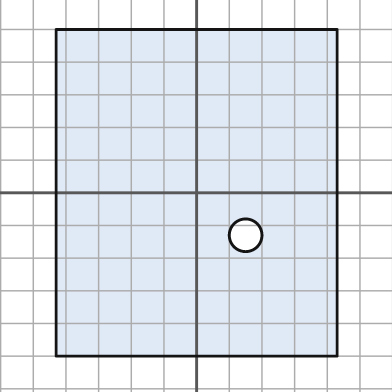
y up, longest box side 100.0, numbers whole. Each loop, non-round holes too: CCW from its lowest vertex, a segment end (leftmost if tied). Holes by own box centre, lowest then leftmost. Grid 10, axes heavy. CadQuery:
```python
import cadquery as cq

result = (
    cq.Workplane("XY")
    .moveTo(-43.0, -50.0)
    .lineTo(43.0, -50.0)
    .lineTo(43.0, 50.0)
    .lineTo(-43.0, 50.0)
    .close()
    .moveTo(15.0, -13.0)
    .circle(5.0)
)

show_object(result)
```